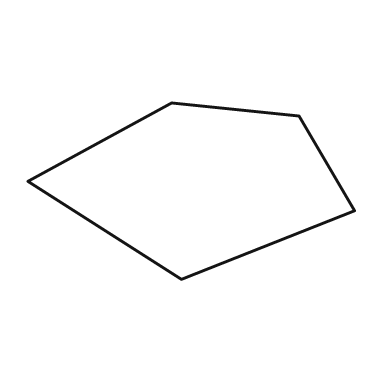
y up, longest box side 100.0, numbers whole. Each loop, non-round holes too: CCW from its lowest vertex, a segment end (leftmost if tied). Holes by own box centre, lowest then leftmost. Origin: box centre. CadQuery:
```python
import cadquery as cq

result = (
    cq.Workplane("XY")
    .moveTo(-3.0, -27.0)
    .lineTo(50.0, -6.0)
    .lineTo(33.0, 23.0)
    .lineTo(-6.0, 27.0)
    .lineTo(-50.0, 3.0)
    .close()
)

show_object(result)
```